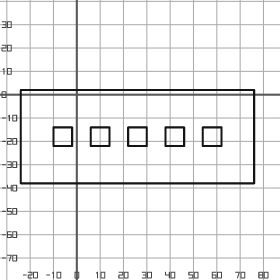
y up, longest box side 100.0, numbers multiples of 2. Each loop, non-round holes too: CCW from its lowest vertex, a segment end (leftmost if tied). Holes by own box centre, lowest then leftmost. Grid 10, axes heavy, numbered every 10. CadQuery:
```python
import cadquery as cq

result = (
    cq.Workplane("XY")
    .moveTo(-24.0, -38.0)
    .lineTo(76.0, -38.0)
    .lineTo(76.0, 2.0)
    .lineTo(-24.0, 2.0)
    .close()
    .moveTo(-10.0, -22.0)
    .lineTo(-2.0, -22.0)
    .lineTo(-2.0, -14.0)
    .lineTo(-10.0, -14.0)
    .close()
    .moveTo(6.0, -22.0)
    .lineTo(14.0, -22.0)
    .lineTo(14.0, -14.0)
    .lineTo(6.0, -14.0)
    .close()
    .moveTo(22.0, -22.0)
    .lineTo(30.0, -22.0)
    .lineTo(30.0, -14.0)
    .lineTo(22.0, -14.0)
    .close()
    .moveTo(38.0, -22.0)
    .lineTo(46.0, -22.0)
    .lineTo(46.0, -14.0)
    .lineTo(38.0, -14.0)
    .close()
    .moveTo(54.0, -22.0)
    .lineTo(62.0, -22.0)
    .lineTo(62.0, -14.0)
    .lineTo(54.0, -14.0)
    .close()
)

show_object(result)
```